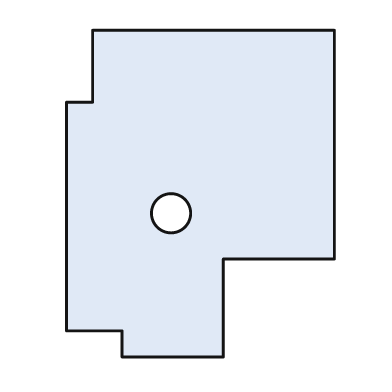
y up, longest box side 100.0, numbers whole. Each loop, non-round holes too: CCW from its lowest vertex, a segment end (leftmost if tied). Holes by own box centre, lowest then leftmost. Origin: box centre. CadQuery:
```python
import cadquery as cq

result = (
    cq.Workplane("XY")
    .moveTo(-24.0, -50.0)
    .lineTo(7.0, -50.0)
    .lineTo(7.0, -20.0)
    .lineTo(41.0, -20.0)
    .lineTo(41.0, 50.0)
    .lineTo(-33.0, 50.0)
    .lineTo(-33.0, 28.0)
    .lineTo(-41.0, 28.0)
    .lineTo(-41.0, -42.0)
    .lineTo(-24.0, -42.0)
    .close()
    .moveTo(-9.0, -6.0)
    .circle(6.0)
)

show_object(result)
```